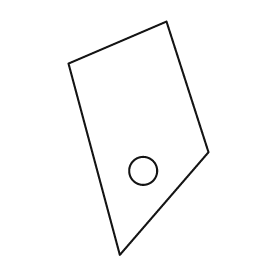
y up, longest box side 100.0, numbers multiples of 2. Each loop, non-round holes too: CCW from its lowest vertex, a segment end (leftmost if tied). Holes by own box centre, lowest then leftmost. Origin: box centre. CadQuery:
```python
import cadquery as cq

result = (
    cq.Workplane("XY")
    .moveTo(-8.0, -50.0)
    .lineTo(30.0, -6.0)
    .lineTo(12.0, 50.0)
    .lineTo(-30.0, 32.0)
    .close()
    .moveTo(2.0, -14.0)
    .circle(6.0)
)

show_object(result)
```